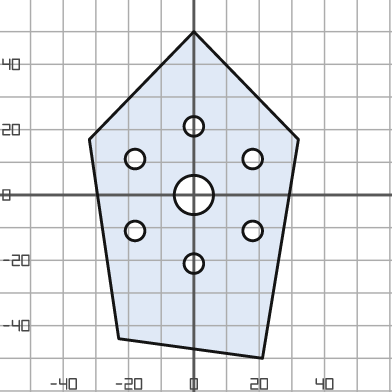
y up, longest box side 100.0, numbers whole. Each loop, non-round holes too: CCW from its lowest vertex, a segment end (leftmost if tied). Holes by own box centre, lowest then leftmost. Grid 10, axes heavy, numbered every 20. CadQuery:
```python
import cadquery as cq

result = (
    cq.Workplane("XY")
    .moveTo(21.0, -50.0)
    .lineTo(32.0, 17.0)
    .lineTo(0.0, 50.0)
    .lineTo(-32.0, 17.0)
    .lineTo(-23.0, -44.0)
    .close()
    .moveTo(0.0, -21.0)
    .circle(3.0)
    .moveTo(-18.0, -11.0)
    .circle(3.0)
    .moveTo(18.0, -11.0)
    .circle(3.0)
    .moveTo(0.0, 0.0)
    .circle(6.0)
    .moveTo(-18.0, 11.0)
    .circle(3.0)
    .moveTo(18.0, 11.0)
    .circle(3.0)
    .moveTo(0.0, 21.0)
    .circle(3.0)
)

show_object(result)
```